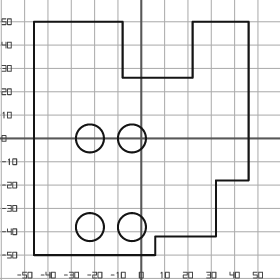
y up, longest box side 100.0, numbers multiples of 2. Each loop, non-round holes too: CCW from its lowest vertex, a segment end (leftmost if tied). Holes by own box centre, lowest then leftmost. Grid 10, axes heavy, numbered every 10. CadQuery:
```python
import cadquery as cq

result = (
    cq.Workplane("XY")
    .moveTo(-46.0, -50.0)
    .lineTo(6.0, -50.0)
    .lineTo(6.0, -42.0)
    .lineTo(32.0, -42.0)
    .lineTo(32.0, -18.0)
    .lineTo(46.0, -18.0)
    .lineTo(46.0, 50.0)
    .lineTo(22.0, 50.0)
    .lineTo(22.0, 26.0)
    .lineTo(-8.0, 26.0)
    .lineTo(-8.0, 50.0)
    .lineTo(-46.0, 50.0)
    .close()
    .moveTo(-22.0, -38.0)
    .circle(6.0)
    .moveTo(-4.0, -38.0)
    .circle(6.0)
    .moveTo(-22.0, 0.0)
    .circle(6.0)
    .moveTo(-4.0, 0.0)
    .circle(6.0)
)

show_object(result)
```